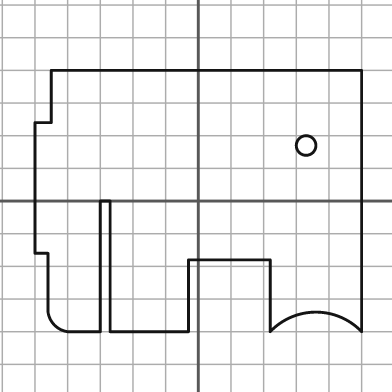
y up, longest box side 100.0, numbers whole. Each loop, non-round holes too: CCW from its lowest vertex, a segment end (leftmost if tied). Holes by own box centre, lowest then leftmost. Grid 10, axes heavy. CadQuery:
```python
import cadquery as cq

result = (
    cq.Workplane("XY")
    .moveTo(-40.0, -40.0)
    .lineTo(-30.0, -40.0)
    .lineTo(-30.0, 0.0)
    .lineTo(-27.0, 0.0)
    .lineTo(-27.0, -40.0)
    .lineTo(-3.0, -40.0)
    .lineTo(-3.0, -18.0)
    .lineTo(22.0, -18.0)
    .lineTo(22.0, -40.0)
    .threePointArc((36.0, -34.0), (50.0, -40.0))
    .lineTo(50.0, 40.0)
    .lineTo(-45.0, 40.0)
    .lineTo(-45.0, 24.0)
    .lineTo(-50.0, 24.0)
    .lineTo(-50.0, -16.0)
    .lineTo(-46.0, -16.0)
    .lineTo(-46.0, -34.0)
    .threePointArc((-44.0, -38.0), (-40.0, -40.0))
    .close()
    .moveTo(33.0, 17.0)
    .circle(3.0)
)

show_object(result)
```